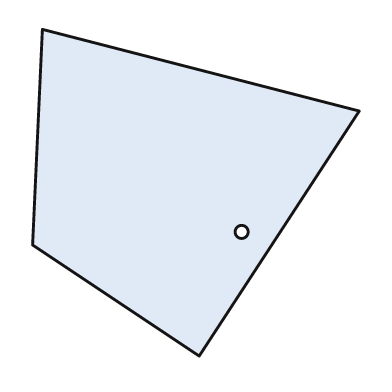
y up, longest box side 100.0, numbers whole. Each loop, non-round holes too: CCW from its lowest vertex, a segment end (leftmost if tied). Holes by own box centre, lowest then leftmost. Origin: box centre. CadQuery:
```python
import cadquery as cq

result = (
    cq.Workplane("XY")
    .moveTo(1.0, -50.0)
    .lineTo(50.0, 25.0)
    .lineTo(-47.0, 50.0)
    .lineTo(-50.0, -16.0)
    .close()
    .moveTo(14.0, -12.0)
    .circle(2.0)
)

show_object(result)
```